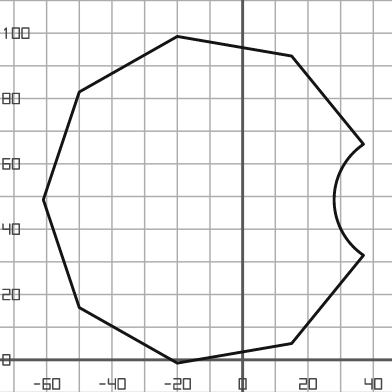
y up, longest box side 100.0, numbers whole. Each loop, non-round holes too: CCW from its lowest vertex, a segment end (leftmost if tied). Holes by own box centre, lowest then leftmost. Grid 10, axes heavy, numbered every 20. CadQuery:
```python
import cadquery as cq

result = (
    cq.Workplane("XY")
    .moveTo(-20.0, -1.0)
    .lineTo(15.0, 5.0)
    .lineTo(37.0, 32.0)
    .threePointArc((28.0, 49.0), (37.0, 66.0))
    .lineTo(15.0, 93.0)
    .lineTo(-20.0, 99.0)
    .lineTo(-50.0, 82.0)
    .lineTo(-61.0, 49.0)
    .lineTo(-50.0, 16.0)
    .close()
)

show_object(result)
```